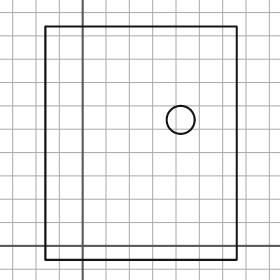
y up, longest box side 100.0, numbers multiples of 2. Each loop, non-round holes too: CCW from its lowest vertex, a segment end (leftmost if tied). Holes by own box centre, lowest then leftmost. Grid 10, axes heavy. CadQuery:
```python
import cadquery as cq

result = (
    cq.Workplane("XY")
    .moveTo(-16.0, -6.0)
    .lineTo(66.0, -6.0)
    .lineTo(66.0, 94.0)
    .lineTo(-16.0, 94.0)
    .close()
    .moveTo(42.0, 54.0)
    .circle(6.0)
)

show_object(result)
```